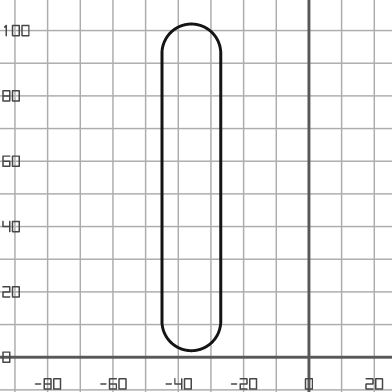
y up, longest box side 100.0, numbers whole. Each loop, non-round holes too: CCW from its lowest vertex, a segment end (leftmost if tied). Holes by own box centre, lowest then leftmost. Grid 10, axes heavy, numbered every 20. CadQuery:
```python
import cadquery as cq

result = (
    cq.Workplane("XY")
    .moveTo(-45.0, 11.0)
    .threePointArc((-36.0, 2.0), (-27.0, 11.0))
    .lineTo(-27.0, 93.0)
    .threePointArc((-36.0, 102.0), (-45.0, 93.0))
    .close()
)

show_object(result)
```